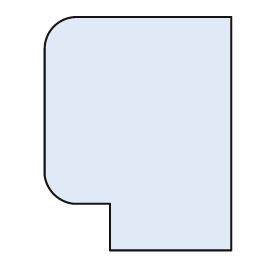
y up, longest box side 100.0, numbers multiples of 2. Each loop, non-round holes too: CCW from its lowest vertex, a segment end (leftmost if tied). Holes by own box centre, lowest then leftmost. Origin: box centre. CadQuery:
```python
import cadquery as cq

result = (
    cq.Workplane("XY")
    .moveTo(-12.0, -50.0)
    .lineTo(40.0, -50.0)
    .lineTo(40.0, 50.0)
    .lineTo(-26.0, 50.0)
    .threePointArc((-36.0, 46.0), (-40.0, 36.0))
    .lineTo(-40.0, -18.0)
    .threePointArc((-36.0, -26.0), (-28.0, -30.0))
    .lineTo(-12.0, -30.0)
    .close()
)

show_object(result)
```